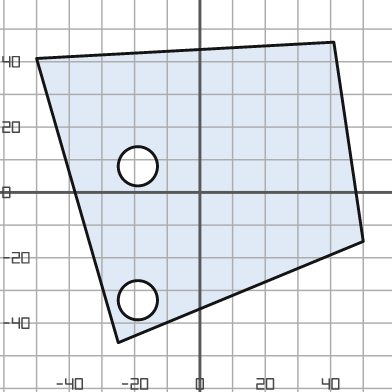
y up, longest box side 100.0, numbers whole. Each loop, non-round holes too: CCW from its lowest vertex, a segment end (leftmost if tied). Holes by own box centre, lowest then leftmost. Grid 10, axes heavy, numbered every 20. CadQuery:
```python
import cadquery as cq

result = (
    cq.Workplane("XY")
    .moveTo(-25.0, -46.0)
    .lineTo(50.0, -15.0)
    .lineTo(41.0, 46.0)
    .lineTo(-50.0, 41.0)
    .close()
    .moveTo(-19.0, -33.0)
    .circle(6.0)
    .moveTo(-19.0, 8.0)
    .circle(6.0)
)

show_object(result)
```